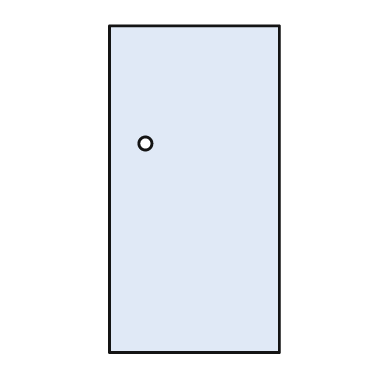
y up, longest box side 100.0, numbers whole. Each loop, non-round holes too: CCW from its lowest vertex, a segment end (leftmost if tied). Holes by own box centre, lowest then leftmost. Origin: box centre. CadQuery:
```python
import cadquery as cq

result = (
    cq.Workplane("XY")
    .moveTo(-26.0, -50.0)
    .lineTo(26.0, -50.0)
    .lineTo(26.0, 50.0)
    .lineTo(-26.0, 50.0)
    .close()
    .moveTo(-15.0, 14.0)
    .circle(2.0)
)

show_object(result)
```